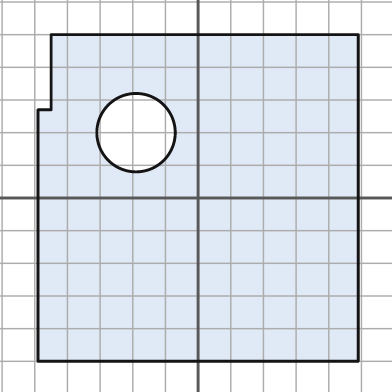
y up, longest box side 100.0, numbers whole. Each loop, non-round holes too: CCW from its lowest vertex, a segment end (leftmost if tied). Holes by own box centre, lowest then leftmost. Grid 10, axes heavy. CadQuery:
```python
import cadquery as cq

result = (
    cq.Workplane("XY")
    .moveTo(-49.0, -50.0)
    .lineTo(49.0, -50.0)
    .lineTo(49.0, 50.0)
    .lineTo(-45.0, 50.0)
    .lineTo(-45.0, 27.0)
    .lineTo(-49.0, 27.0)
    .close()
    .moveTo(-19.0, 20.0)
    .circle(12.0)
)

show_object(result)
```